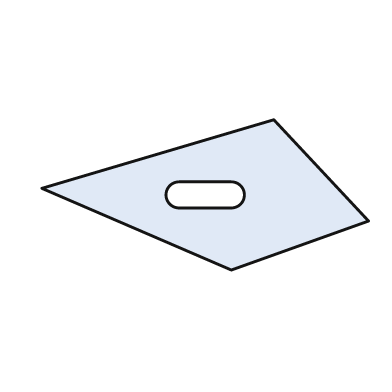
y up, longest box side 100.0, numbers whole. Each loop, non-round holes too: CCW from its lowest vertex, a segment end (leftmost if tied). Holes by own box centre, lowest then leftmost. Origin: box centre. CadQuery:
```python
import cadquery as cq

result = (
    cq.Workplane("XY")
    .moveTo(8.0, -23.0)
    .lineTo(50.0, -8.0)
    .lineTo(21.0, 23.0)
    .lineTo(-50.0, 2.0)
    .close()
    .moveTo(-8.0, -4.0)
    .lineTo(8.0, -4.0)
    .threePointArc((12.0, 0.0), (8.0, 4.0))
    .lineTo(-8.0, 4.0)
    .threePointArc((-12.0, 0.0), (-8.0, -4.0))
    .close()
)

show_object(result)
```